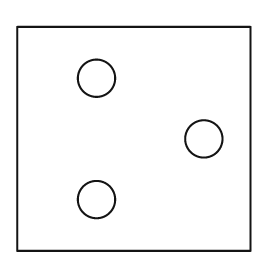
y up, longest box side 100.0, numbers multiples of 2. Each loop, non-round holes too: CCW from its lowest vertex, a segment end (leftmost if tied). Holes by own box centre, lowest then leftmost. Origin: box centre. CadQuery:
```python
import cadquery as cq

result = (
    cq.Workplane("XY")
    .moveTo(-50.0, -48.0)
    .lineTo(50.0, -48.0)
    .lineTo(50.0, 48.0)
    .lineTo(-50.0, 48.0)
    .close()
    .moveTo(-16.0, -26.0)
    .circle(8.0)
    .moveTo(30.0, 0.0)
    .circle(8.0)
    .moveTo(-16.0, 26.0)
    .circle(8.0)
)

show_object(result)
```